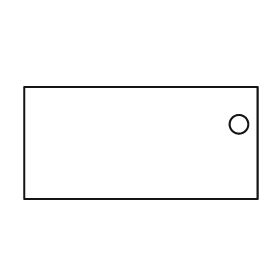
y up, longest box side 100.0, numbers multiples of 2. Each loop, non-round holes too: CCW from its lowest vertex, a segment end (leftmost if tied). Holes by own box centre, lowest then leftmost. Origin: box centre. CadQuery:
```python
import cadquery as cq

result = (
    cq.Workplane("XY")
    .moveTo(-50.0, -24.0)
    .lineTo(50.0, -24.0)
    .lineTo(50.0, 24.0)
    .lineTo(-50.0, 24.0)
    .close()
    .moveTo(42.0, 8.0)
    .circle(4.0)
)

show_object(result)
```